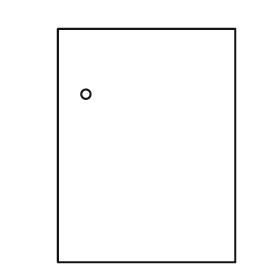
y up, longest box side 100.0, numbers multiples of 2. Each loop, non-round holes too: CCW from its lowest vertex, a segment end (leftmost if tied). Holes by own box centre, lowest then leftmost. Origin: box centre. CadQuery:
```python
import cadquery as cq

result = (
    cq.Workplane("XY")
    .moveTo(-38.0, -50.0)
    .lineTo(38.0, -50.0)
    .lineTo(38.0, 50.0)
    .lineTo(-38.0, 50.0)
    .close()
    .moveTo(-26.0, 22.0)
    .circle(2.0)
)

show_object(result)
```